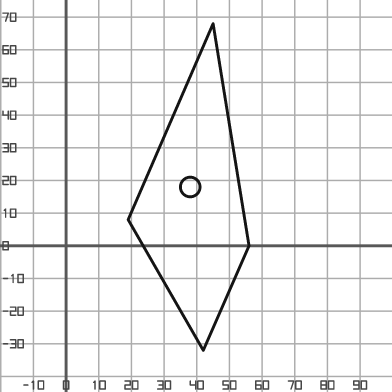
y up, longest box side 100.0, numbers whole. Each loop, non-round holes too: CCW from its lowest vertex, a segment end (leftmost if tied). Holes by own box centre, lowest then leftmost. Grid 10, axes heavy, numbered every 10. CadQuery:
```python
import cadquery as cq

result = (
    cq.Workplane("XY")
    .moveTo(42.0, -32.0)
    .lineTo(56.0, 0.0)
    .lineTo(45.0, 68.0)
    .lineTo(19.0, 8.0)
    .close()
    .moveTo(38.0, 18.0)
    .circle(3.0)
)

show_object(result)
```